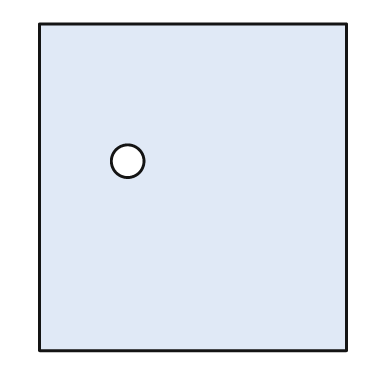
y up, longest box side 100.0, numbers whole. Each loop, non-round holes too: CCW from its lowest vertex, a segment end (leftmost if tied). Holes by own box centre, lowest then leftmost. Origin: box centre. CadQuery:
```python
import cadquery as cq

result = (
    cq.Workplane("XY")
    .moveTo(-47.0, -50.0)
    .lineTo(47.0, -50.0)
    .lineTo(47.0, 50.0)
    .lineTo(-47.0, 50.0)
    .close()
    .moveTo(-20.0, 8.0)
    .circle(5.0)
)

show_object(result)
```